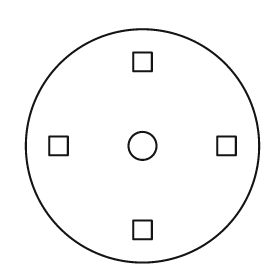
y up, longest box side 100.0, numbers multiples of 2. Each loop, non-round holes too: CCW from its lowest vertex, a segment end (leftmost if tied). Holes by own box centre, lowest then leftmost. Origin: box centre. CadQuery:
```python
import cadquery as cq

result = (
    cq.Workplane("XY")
    .moveTo(0.0, 0.0)
    .circle(50.0)
    .moveTo(-4.0, -40.0)
    .lineTo(4.0, -40.0)
    .lineTo(4.0, -32.0)
    .lineTo(-4.0, -32.0)
    .close()
    .moveTo(-40.0, -4.0)
    .lineTo(-32.0, -4.0)
    .lineTo(-32.0, 4.0)
    .lineTo(-40.0, 4.0)
    .close()
    .moveTo(0.0, 0.0)
    .circle(6.0)
    .moveTo(32.0, -4.0)
    .lineTo(40.0, -4.0)
    .lineTo(40.0, 4.0)
    .lineTo(32.0, 4.0)
    .close()
    .moveTo(-4.0, 32.0)
    .lineTo(4.0, 32.0)
    .lineTo(4.0, 40.0)
    .lineTo(-4.0, 40.0)
    .close()
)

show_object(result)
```